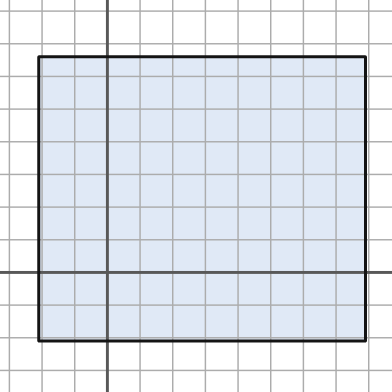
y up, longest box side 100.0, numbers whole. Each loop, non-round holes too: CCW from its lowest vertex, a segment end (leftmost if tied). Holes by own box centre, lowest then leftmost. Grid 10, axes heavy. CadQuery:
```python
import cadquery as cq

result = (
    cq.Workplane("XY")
    .moveTo(-21.0, -21.0)
    .lineTo(79.0, -21.0)
    .lineTo(79.0, 66.0)
    .lineTo(-21.0, 66.0)
    .close()
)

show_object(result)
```